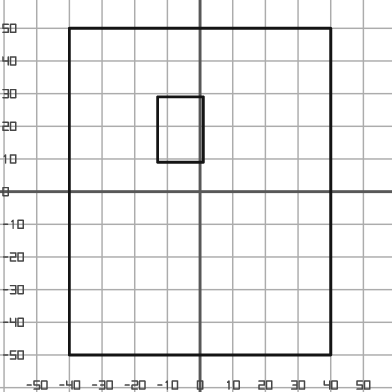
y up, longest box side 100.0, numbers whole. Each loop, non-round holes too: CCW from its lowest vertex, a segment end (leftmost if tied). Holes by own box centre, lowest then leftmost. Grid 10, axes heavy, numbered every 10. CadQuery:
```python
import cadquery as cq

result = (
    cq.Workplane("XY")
    .moveTo(-40.0, -50.0)
    .lineTo(40.0, -50.0)
    .lineTo(40.0, 50.0)
    .lineTo(-40.0, 50.0)
    .close()
    .moveTo(-13.0, 9.0)
    .lineTo(1.0, 9.0)
    .lineTo(1.0, 29.0)
    .lineTo(-13.0, 29.0)
    .close()
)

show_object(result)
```